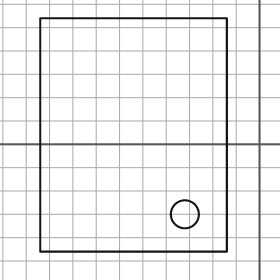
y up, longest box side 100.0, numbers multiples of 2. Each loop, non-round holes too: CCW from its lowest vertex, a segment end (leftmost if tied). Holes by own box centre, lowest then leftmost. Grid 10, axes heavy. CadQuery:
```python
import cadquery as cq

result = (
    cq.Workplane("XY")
    .moveTo(-94.0, -46.0)
    .lineTo(-14.0, -46.0)
    .lineTo(-14.0, 54.0)
    .lineTo(-94.0, 54.0)
    .close()
    .moveTo(-32.0, -30.0)
    .circle(6.0)
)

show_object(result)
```